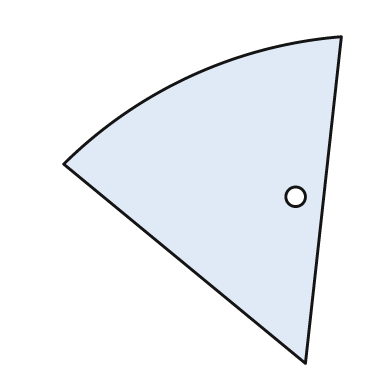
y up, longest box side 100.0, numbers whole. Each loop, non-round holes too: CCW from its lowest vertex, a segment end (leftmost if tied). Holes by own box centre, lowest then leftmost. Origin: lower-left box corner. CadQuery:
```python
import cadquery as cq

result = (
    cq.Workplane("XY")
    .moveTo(74.0, 0.0)
    .lineTo(85.0, 100.0)
    .threePointArc((39.0, 88.0), (0.0, 61.0))
    .close()
    .moveTo(71.0, 51.0)
    .circle(3.0)
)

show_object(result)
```